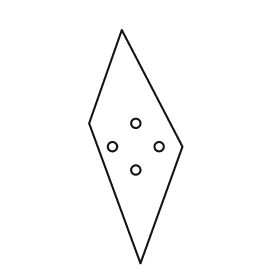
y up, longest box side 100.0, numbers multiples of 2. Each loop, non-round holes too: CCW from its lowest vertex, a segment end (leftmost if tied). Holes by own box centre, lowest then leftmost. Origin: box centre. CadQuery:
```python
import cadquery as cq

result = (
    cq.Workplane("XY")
    .moveTo(2.0, -50.0)
    .lineTo(20.0, 0.0)
    .lineTo(-6.0, 50.0)
    .lineTo(-20.0, 10.0)
    .close()
    .moveTo(0.0, -10.0)
    .circle(2.0)
    .moveTo(-10.0, 0.0)
    .circle(2.0)
    .moveTo(10.0, 0.0)
    .circle(2.0)
    .moveTo(0.0, 10.0)
    .circle(2.0)
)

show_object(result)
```